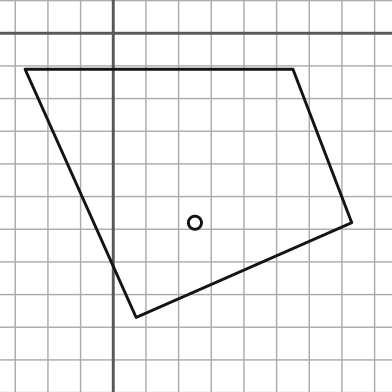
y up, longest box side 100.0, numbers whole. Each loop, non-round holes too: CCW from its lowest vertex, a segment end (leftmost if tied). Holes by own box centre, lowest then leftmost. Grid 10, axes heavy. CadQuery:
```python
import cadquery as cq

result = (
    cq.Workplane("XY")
    .moveTo(7.0, -87.0)
    .lineTo(73.0, -58.0)
    .lineTo(55.0, -11.0)
    .lineTo(-27.0, -11.0)
    .close()
    .moveTo(25.0, -58.0)
    .circle(2.0)
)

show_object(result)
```